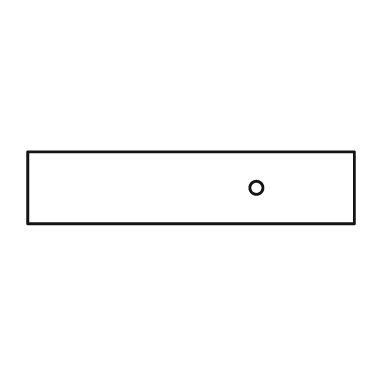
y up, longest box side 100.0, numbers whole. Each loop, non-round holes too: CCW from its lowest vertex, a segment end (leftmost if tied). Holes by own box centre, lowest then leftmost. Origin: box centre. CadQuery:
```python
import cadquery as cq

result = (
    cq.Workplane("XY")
    .moveTo(-50.0, -11.0)
    .lineTo(50.0, -11.0)
    .lineTo(50.0, 11.0)
    .lineTo(-50.0, 11.0)
    .close()
    .moveTo(20.0, 0.0)
    .circle(2.0)
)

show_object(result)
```